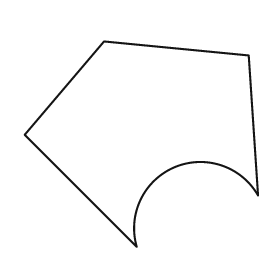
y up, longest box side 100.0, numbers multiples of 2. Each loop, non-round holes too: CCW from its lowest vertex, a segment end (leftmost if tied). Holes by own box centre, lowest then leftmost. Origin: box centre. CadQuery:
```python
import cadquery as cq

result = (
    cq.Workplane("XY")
    .moveTo(-2.0, -44.0)
    .threePointArc((14.0, -10.0), (50.0, -22.0))
    .lineTo(46.0, 38.0)
    .lineTo(-16.0, 44.0)
    .lineTo(-50.0, 4.0)
    .close()
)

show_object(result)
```